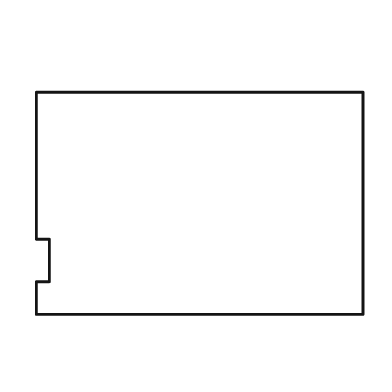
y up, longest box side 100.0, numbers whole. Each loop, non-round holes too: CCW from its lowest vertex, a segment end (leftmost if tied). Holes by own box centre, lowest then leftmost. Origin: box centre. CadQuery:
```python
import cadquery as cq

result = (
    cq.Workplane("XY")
    .moveTo(-50.0, -34.0)
    .lineTo(50.0, -34.0)
    .lineTo(50.0, 34.0)
    .lineTo(-50.0, 34.0)
    .lineTo(-50.0, -11.0)
    .lineTo(-46.0, -11.0)
    .lineTo(-46.0, -24.0)
    .lineTo(-50.0, -24.0)
    .close()
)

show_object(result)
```